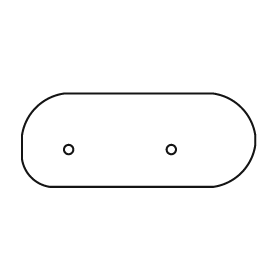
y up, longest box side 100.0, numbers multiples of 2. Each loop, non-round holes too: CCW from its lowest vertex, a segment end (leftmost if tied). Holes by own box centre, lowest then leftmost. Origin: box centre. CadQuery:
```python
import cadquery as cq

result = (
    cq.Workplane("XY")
    .moveTo(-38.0, -20.0)
    .lineTo(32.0, -20.0)
    .threePointArc((44.0, -14.0), (50.0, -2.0))
    .lineTo(50.0, 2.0)
    .threePointArc((44.0, 14.0), (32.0, 20.0))
    .lineTo(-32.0, 20.0)
    .threePointArc((-44.0, 14.0), (-50.0, 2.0))
    .lineTo(-50.0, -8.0)
    .threePointArc((-46.0, -16.0), (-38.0, -20.0))
    .close()
    .moveTo(-30.0, -4.0)
    .circle(2.0)
    .moveTo(14.0, -4.0)
    .circle(2.0)
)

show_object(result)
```